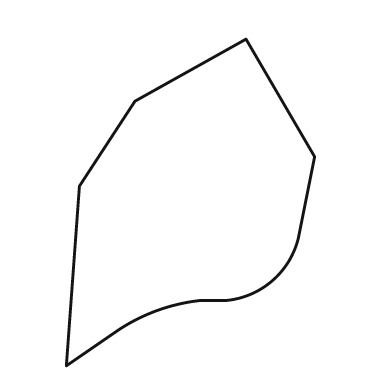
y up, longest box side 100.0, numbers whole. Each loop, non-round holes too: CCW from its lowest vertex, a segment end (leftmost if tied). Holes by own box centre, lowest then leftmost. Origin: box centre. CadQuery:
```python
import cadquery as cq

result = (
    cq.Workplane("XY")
    .moveTo(-38.0, -50.0)
    .lineTo(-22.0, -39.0)
    .threePointArc((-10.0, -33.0), (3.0, -30.0))
    .lineTo(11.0, -30.0)
    .threePointArc((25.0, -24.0), (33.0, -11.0))
    .lineTo(38.0, 14.0)
    .lineTo(17.0, 50.0)
    .lineTo(-17.0, 31.0)
    .lineTo(-34.0, 5.0)
    .close()
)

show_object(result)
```